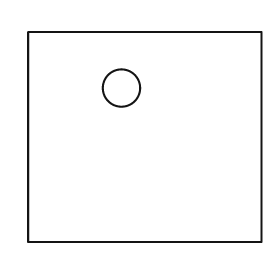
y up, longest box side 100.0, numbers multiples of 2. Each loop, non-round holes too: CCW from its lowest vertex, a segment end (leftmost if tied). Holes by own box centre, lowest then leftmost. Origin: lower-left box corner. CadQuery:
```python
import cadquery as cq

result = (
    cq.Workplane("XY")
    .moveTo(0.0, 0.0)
    .lineTo(100.0, 0.0)
    .lineTo(100.0, 90.0)
    .lineTo(0.0, 90.0)
    .close()
    .moveTo(40.0, 66.0)
    .circle(8.0)
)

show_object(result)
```